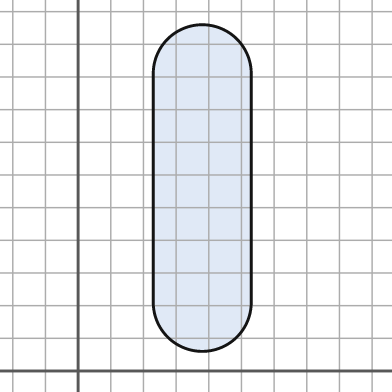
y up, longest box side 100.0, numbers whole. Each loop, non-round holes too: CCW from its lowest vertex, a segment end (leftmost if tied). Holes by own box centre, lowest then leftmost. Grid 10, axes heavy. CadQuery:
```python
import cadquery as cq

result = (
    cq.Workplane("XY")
    .moveTo(23.0, 21.0)
    .threePointArc((38.0, 6.0), (53.0, 21.0))
    .lineTo(53.0, 91.0)
    .threePointArc((38.0, 106.0), (23.0, 91.0))
    .close()
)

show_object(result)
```